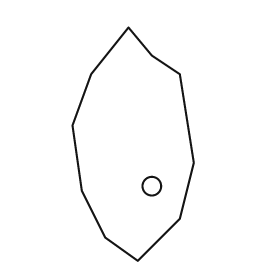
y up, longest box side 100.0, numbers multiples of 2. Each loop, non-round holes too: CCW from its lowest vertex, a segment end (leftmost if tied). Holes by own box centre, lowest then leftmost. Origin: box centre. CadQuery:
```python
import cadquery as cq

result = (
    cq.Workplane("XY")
    .moveTo(2.0, -50.0)
    .lineTo(20.0, -32.0)
    .lineTo(26.0, -8.0)
    .lineTo(20.0, 30.0)
    .lineTo(8.0, 38.0)
    .lineTo(-2.0, 50.0)
    .lineTo(-18.0, 30.0)
    .lineTo(-26.0, 8.0)
    .lineTo(-22.0, -20.0)
    .lineTo(-12.0, -40.0)
    .close()
    .moveTo(8.0, -18.0)
    .circle(4.0)
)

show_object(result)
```